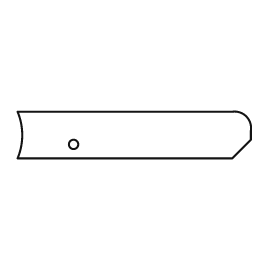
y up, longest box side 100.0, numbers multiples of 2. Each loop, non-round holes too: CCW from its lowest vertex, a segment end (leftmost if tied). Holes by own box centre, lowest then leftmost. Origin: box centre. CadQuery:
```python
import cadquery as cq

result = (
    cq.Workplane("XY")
    .moveTo(-50.0, -10.0)
    .lineTo(42.0, -10.0)
    .lineTo(50.0, -2.0)
    .lineTo(50.0, 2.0)
    .threePointArc((48.0, 8.0), (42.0, 10.0))
    .lineTo(-50.0, 10.0)
    .threePointArc((-48.0, 0.0), (-50.0, -10.0))
    .close()
    .moveTo(-26.0, -4.0)
    .circle(2.0)
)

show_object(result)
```